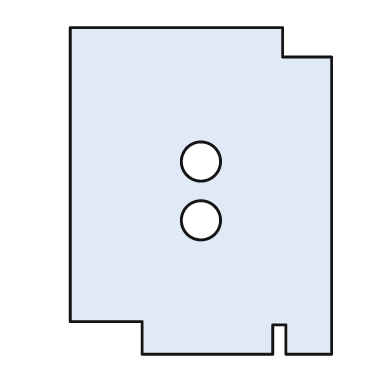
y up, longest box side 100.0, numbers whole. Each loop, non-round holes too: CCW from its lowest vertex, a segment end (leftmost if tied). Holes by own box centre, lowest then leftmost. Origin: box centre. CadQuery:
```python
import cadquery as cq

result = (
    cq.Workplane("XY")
    .moveTo(-18.0, -50.0)
    .lineTo(22.0, -50.0)
    .lineTo(22.0, -41.0)
    .lineTo(26.0, -41.0)
    .lineTo(26.0, -50.0)
    .lineTo(40.0, -50.0)
    .lineTo(40.0, 41.0)
    .lineTo(25.0, 41.0)
    .lineTo(25.0, 50.0)
    .lineTo(-40.0, 50.0)
    .lineTo(-40.0, -40.0)
    .lineTo(-18.0, -40.0)
    .close()
    .moveTo(0.0, -9.0)
    .circle(6.0)
    .moveTo(0.0, 9.0)
    .circle(6.0)
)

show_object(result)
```